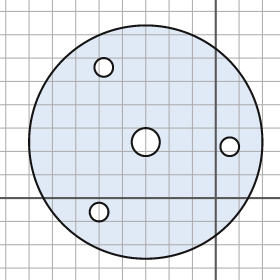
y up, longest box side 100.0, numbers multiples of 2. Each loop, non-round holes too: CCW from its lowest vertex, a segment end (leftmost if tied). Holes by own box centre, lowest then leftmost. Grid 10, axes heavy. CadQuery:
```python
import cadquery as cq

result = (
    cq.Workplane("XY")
    .moveTo(-30.0, 24.0)
    .circle(50.0)
    .moveTo(-50.0, -6.0)
    .circle(4.0)
    .moveTo(6.0, 22.0)
    .circle(4.0)
    .moveTo(-30.0, 24.0)
    .circle(6.0)
    .moveTo(-48.0, 56.0)
    .circle(4.0)
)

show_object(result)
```